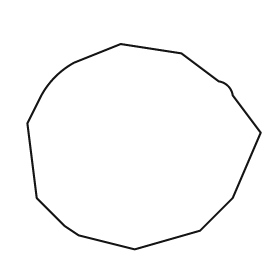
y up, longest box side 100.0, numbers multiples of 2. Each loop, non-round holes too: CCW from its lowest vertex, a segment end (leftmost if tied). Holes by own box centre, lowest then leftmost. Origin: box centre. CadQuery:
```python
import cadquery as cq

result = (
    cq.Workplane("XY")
    .moveTo(-4.0, -44.0)
    .lineTo(24.0, -36.0)
    .lineTo(38.0, -22.0)
    .lineTo(50.0, 6.0)
    .lineTo(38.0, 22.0)
    .threePointArc((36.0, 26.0), (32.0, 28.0))
    .lineTo(16.0, 40.0)
    .lineTo(-10.0, 44.0)
    .lineTo(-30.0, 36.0)
    .threePointArc((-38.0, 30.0), (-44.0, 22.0))
    .lineTo(-50.0, 10.0)
    .lineTo(-46.0, -22.0)
    .lineTo(-34.0, -34.0)
    .lineTo(-28.0, -38.0)
    .close()
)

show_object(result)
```